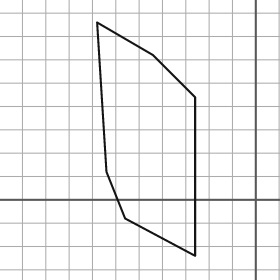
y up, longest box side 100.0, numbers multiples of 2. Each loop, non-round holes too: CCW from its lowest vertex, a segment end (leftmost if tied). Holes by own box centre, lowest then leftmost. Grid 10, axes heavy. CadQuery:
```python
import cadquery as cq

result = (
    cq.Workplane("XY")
    .moveTo(-26.0, -24.0)
    .lineTo(-26.0, 44.0)
    .lineTo(-44.0, 62.0)
    .lineTo(-68.0, 76.0)
    .lineTo(-64.0, 12.0)
    .lineTo(-56.0, -8.0)
    .close()
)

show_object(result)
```